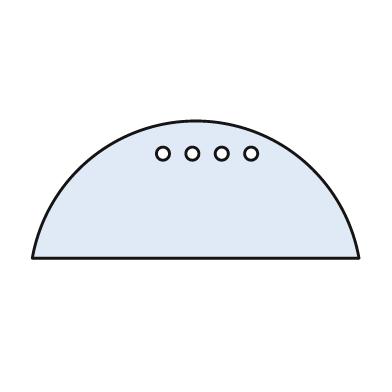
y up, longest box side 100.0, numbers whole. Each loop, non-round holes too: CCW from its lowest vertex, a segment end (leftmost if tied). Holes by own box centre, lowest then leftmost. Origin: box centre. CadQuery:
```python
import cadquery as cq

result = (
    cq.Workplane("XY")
    .moveTo(-50.0, -21.0)
    .lineTo(50.0, -21.0)
    .threePointArc((0.0, 21.0), (-50.0, -21.0))
    .close()
    .moveTo(-10.0, 11.0)
    .circle(2.0)
    .moveTo(-1.0, 11.0)
    .circle(2.0)
    .moveTo(8.0, 11.0)
    .circle(2.0)
    .moveTo(17.0, 11.0)
    .circle(2.0)
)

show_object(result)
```